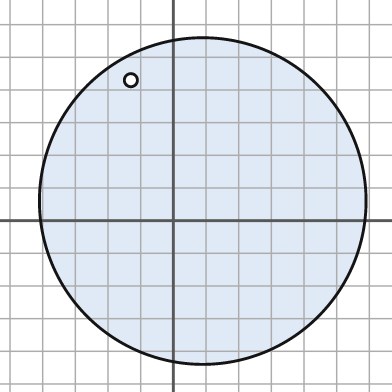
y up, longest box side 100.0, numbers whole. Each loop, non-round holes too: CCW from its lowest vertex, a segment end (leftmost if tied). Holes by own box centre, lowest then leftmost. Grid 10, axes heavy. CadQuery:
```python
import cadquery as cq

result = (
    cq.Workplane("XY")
    .moveTo(9.0, 6.0)
    .circle(50.0)
    .moveTo(-13.0, 43.0)
    .circle(2.0)
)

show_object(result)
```